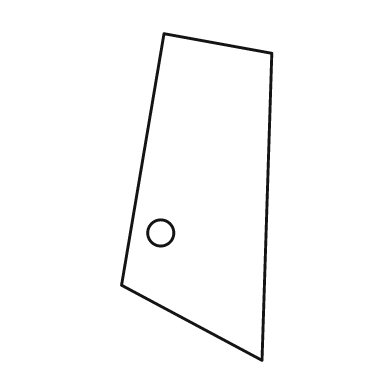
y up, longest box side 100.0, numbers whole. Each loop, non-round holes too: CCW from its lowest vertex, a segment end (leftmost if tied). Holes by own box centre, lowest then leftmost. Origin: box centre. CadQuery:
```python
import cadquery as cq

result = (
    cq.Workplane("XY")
    .moveTo(20.0, -50.0)
    .lineTo(23.0, 44.0)
    .lineTo(-10.0, 50.0)
    .lineTo(-23.0, -27.0)
    .close()
    .moveTo(-11.0, -11.0)
    .circle(4.0)
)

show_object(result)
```